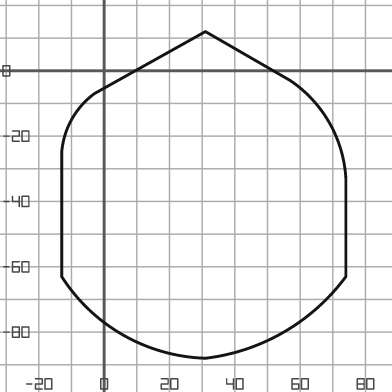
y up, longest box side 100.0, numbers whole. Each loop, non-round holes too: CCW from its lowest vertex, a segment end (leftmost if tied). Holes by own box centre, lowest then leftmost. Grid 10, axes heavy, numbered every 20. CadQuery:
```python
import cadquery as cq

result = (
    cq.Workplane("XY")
    .moveTo(31.0, -88.0)
    .threePointArc((55.0, -80.0), (74.0, -63.0))
    .lineTo(74.0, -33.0)
    .threePointArc((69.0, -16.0), (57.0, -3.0))
    .lineTo(31.0, 12.0)
    .lineTo(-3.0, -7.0)
    .threePointArc((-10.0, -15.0), (-13.0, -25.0))
    .lineTo(-13.0, -63.0)
    .threePointArc((6.0, -81.0), (31.0, -88.0))
    .close()
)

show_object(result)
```